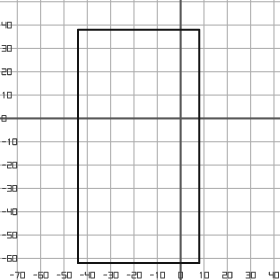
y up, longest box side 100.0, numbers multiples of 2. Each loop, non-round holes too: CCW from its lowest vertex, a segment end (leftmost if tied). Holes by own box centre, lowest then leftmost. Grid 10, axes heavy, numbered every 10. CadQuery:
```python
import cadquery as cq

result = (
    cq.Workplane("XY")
    .moveTo(-44.0, -62.0)
    .lineTo(8.0, -62.0)
    .lineTo(8.0, 38.0)
    .lineTo(-44.0, 38.0)
    .close()
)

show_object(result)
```